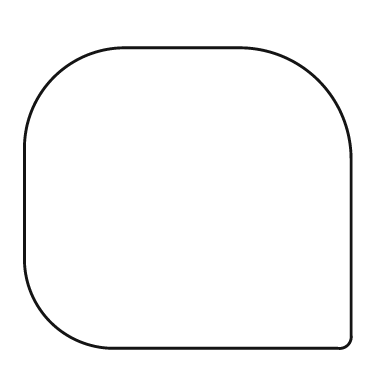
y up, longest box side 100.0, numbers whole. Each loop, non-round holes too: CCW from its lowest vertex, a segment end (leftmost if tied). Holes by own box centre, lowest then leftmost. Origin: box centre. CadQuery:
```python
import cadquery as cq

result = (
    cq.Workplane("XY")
    .moveTo(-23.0, -46.0)
    .lineTo(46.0, -46.0)
    .threePointArc((49.0, -45.0), (50.0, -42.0))
    .lineTo(50.0, 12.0)
    .threePointArc((40.0, 36.0), (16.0, 46.0))
    .lineTo(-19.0, 46.0)
    .threePointArc((-41.0, 37.0), (-50.0, 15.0))
    .lineTo(-50.0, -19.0)
    .threePointArc((-42.0, -38.0), (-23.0, -46.0))
    .close()
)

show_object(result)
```